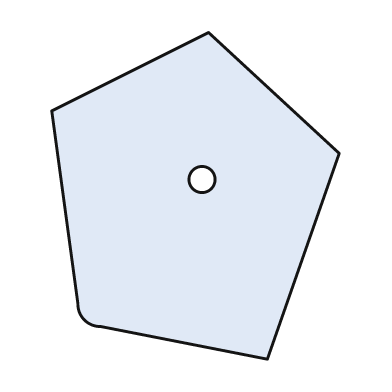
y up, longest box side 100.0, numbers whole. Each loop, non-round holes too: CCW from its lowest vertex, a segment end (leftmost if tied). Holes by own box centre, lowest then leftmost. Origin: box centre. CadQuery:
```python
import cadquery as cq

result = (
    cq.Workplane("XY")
    .moveTo(22.0, -50.0)
    .lineTo(44.0, 13.0)
    .lineTo(4.0, 50.0)
    .lineTo(-44.0, 26.0)
    .lineTo(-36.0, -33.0)
    .threePointArc((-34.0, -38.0), (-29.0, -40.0))
    .close()
    .moveTo(2.0, 5.0)
    .circle(4.0)
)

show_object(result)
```